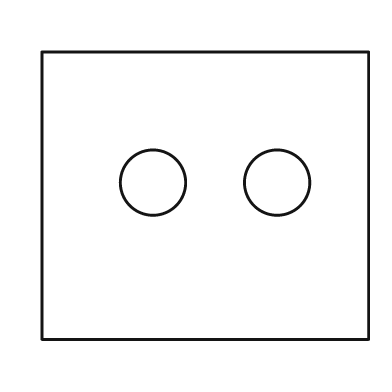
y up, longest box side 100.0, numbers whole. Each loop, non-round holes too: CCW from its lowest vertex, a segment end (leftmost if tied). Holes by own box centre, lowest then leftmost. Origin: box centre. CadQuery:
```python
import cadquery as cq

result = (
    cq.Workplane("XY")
    .moveTo(-50.0, -44.0)
    .lineTo(50.0, -44.0)
    .lineTo(50.0, 44.0)
    .lineTo(-50.0, 44.0)
    .close()
    .moveTo(-16.0, 4.0)
    .circle(10.0)
    .moveTo(22.0, 4.0)
    .circle(10.0)
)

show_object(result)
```